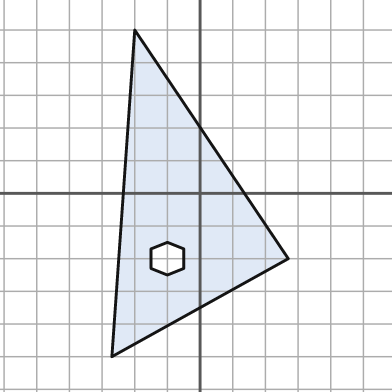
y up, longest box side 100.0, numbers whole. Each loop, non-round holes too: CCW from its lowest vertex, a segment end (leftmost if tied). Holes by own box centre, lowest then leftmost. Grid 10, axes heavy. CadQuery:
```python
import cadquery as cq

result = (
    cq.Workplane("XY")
    .moveTo(-27.0, -50.0)
    .lineTo(27.0, -20.0)
    .lineTo(-20.0, 50.0)
    .close()
    .moveTo(-10.0, -25.0)
    .lineTo(-5.0, -23.0)
    .lineTo(-5.0, -17.0)
    .lineTo(-10.0, -15.0)
    .lineTo(-15.0, -17.0)
    .lineTo(-15.0, -23.0)
    .close()
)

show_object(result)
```